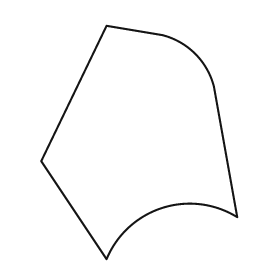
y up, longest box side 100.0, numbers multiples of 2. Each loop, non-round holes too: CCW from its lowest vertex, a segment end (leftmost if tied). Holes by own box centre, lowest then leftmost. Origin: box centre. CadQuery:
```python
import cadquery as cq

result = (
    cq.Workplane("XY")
    .moveTo(-14.0, -50.0)
    .threePointArc((10.0, -28.0), (42.0, -32.0))
    .lineTo(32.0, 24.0)
    .threePointArc((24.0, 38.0), (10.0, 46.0))
    .lineTo(-14.0, 50.0)
    .lineTo(-42.0, -8.0)
    .close()
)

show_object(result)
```